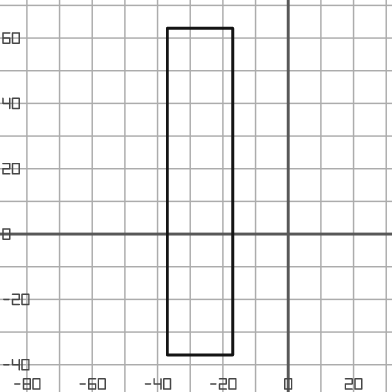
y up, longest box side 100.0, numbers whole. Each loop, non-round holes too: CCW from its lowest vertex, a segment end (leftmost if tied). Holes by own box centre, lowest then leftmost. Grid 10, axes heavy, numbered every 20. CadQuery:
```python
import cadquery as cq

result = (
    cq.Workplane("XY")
    .moveTo(-37.0, -37.0)
    .lineTo(-17.0, -37.0)
    .lineTo(-17.0, 63.0)
    .lineTo(-37.0, 63.0)
    .close()
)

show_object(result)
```